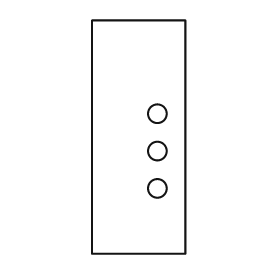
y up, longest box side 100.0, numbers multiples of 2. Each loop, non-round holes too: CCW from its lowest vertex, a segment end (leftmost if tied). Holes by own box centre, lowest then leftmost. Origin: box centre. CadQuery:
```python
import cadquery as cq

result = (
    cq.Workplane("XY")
    .moveTo(-20.0, -50.0)
    .lineTo(20.0, -50.0)
    .lineTo(20.0, 50.0)
    .lineTo(-20.0, 50.0)
    .close()
    .moveTo(8.0, -22.0)
    .circle(4.0)
    .moveTo(8.0, -6.0)
    .circle(4.0)
    .moveTo(8.0, 10.0)
    .circle(4.0)
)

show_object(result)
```